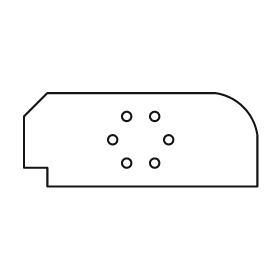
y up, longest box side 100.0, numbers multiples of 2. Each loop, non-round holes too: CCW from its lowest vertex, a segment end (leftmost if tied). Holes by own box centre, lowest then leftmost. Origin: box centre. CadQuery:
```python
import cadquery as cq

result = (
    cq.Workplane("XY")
    .moveTo(-40.0, -20.0)
    .lineTo(50.0, -20.0)
    .lineTo(50.0, 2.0)
    .threePointArc((44.0, 14.0), (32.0, 20.0))
    .lineTo(-40.0, 20.0)
    .lineTo(-50.0, 10.0)
    .lineTo(-50.0, -12.0)
    .lineTo(-40.0, -12.0)
    .close()
    .moveTo(-6.0, -10.0)
    .circle(2.0)
    .moveTo(6.0, -10.0)
    .circle(2.0)
    .moveTo(-12.0, 0.0)
    .circle(2.0)
    .moveTo(12.0, 0.0)
    .circle(2.0)
    .moveTo(-6.0, 10.0)
    .circle(2.0)
    .moveTo(6.0, 10.0)
    .circle(2.0)
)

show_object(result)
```